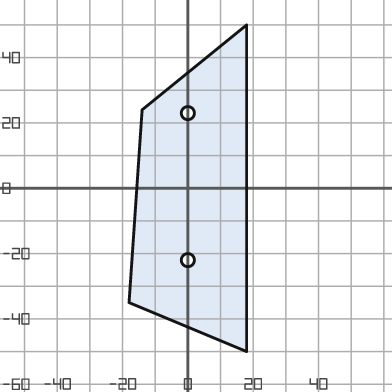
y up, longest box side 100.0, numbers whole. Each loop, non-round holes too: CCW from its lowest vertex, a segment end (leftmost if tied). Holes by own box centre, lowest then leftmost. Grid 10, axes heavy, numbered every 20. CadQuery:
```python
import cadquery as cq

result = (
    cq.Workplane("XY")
    .moveTo(18.0, -50.0)
    .lineTo(18.0, 50.0)
    .lineTo(-14.0, 24.0)
    .lineTo(-18.0, -35.0)
    .close()
    .moveTo(0.0, -22.0)
    .circle(2.0)
    .moveTo(0.0, 23.0)
    .circle(2.0)
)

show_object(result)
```